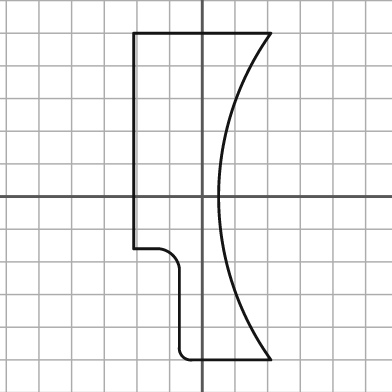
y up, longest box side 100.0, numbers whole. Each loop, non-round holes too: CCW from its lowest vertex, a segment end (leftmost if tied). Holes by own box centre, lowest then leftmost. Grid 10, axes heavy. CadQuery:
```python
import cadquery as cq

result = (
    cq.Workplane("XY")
    .moveTo(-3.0, -50.0)
    .lineTo(21.0, -50.0)
    .threePointArc((5.0, 0.0), (21.0, 50.0))
    .lineTo(-21.0, 50.0)
    .lineTo(-21.0, -16.0)
    .lineTo(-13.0, -16.0)
    .threePointArc((-9.0, -18.0), (-7.0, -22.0))
    .lineTo(-7.0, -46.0)
    .threePointArc((-6.0, -49.0), (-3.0, -50.0))
    .close()
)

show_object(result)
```